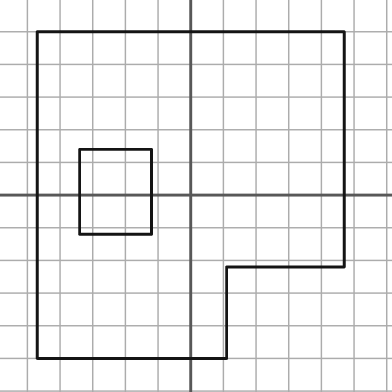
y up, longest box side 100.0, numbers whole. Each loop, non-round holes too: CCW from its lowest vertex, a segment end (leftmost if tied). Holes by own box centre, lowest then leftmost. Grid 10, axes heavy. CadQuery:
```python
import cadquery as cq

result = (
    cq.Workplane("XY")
    .moveTo(-47.0, -50.0)
    .lineTo(11.0, -50.0)
    .lineTo(11.0, -22.0)
    .lineTo(47.0, -22.0)
    .lineTo(47.0, 50.0)
    .lineTo(-47.0, 50.0)
    .close()
    .moveTo(-34.0, -12.0)
    .lineTo(-12.0, -12.0)
    .lineTo(-12.0, 14.0)
    .lineTo(-34.0, 14.0)
    .close()
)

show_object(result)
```